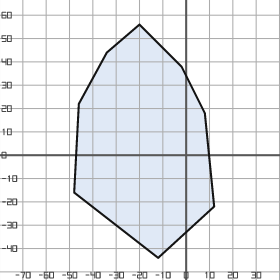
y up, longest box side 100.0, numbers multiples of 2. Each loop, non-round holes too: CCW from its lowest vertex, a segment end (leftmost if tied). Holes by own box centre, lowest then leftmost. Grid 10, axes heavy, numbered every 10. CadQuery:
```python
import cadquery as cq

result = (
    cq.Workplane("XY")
    .moveTo(-12.0, -44.0)
    .lineTo(12.0, -22.0)
    .lineTo(8.0, 18.0)
    .lineTo(-2.0, 38.0)
    .lineTo(-20.0, 56.0)
    .lineTo(-34.0, 44.0)
    .lineTo(-46.0, 22.0)
    .lineTo(-48.0, -16.0)
    .close()
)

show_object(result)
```